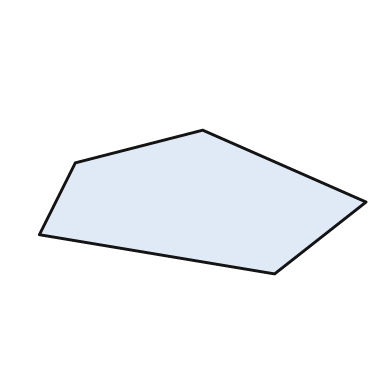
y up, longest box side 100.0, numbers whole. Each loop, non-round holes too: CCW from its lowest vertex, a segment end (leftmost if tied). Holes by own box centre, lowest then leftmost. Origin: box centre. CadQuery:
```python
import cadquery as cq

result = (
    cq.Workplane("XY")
    .moveTo(22.0, -22.0)
    .lineTo(50.0, 0.0)
    .lineTo(0.0, 22.0)
    .lineTo(-39.0, 12.0)
    .lineTo(-50.0, -10.0)
    .close()
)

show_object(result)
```